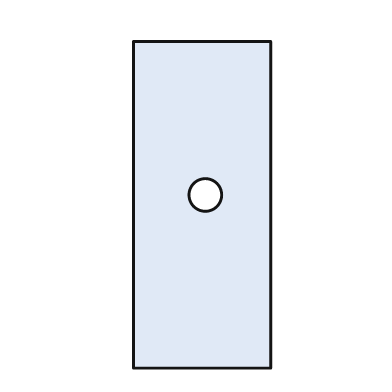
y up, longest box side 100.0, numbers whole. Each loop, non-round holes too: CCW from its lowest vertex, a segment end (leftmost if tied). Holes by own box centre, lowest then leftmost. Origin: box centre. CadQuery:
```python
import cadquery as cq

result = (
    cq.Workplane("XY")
    .moveTo(-21.0, -50.0)
    .lineTo(21.0, -50.0)
    .lineTo(21.0, 50.0)
    .lineTo(-21.0, 50.0)
    .close()
    .moveTo(1.0, 3.0)
    .circle(5.0)
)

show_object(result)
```